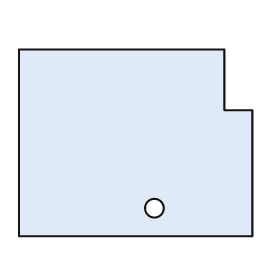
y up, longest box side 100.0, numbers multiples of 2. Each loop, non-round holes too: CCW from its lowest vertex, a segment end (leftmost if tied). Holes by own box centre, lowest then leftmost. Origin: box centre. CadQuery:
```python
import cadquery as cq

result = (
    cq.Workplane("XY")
    .moveTo(-50.0, -40.0)
    .lineTo(50.0, -40.0)
    .lineTo(50.0, 14.0)
    .lineTo(38.0, 14.0)
    .lineTo(38.0, 40.0)
    .lineTo(-50.0, 40.0)
    .close()
    .moveTo(8.0, -28.0)
    .circle(4.0)
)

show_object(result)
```